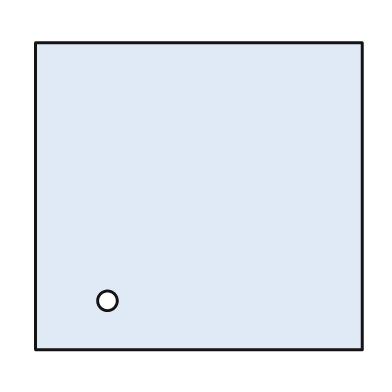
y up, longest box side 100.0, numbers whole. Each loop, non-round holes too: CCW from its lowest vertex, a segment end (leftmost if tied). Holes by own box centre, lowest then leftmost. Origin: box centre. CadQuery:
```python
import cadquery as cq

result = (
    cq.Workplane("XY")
    .moveTo(-50.0, -47.0)
    .lineTo(50.0, -47.0)
    .lineTo(50.0, 47.0)
    .lineTo(-50.0, 47.0)
    .close()
    .moveTo(-28.0, -32.0)
    .circle(3.0)
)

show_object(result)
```